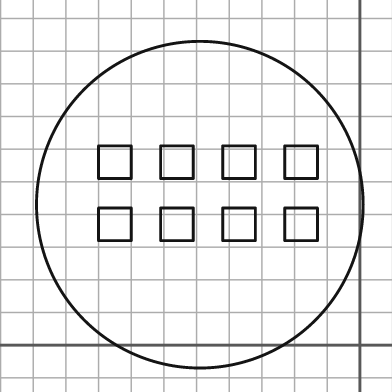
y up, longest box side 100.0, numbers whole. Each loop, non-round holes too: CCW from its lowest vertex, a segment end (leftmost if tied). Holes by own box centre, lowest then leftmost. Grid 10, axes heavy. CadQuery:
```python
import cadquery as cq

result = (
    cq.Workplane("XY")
    .moveTo(-49.0, 43.0)
    .circle(50.0)
    .moveTo(-80.0, 32.0)
    .lineTo(-70.0, 32.0)
    .lineTo(-70.0, 42.0)
    .lineTo(-80.0, 42.0)
    .close()
    .moveTo(-61.0, 32.0)
    .lineTo(-51.0, 32.0)
    .lineTo(-51.0, 42.0)
    .lineTo(-61.0, 42.0)
    .close()
    .moveTo(-42.0, 32.0)
    .lineTo(-32.0, 32.0)
    .lineTo(-32.0, 42.0)
    .lineTo(-42.0, 42.0)
    .close()
    .moveTo(-23.0, 32.0)
    .lineTo(-13.0, 32.0)
    .lineTo(-13.0, 42.0)
    .lineTo(-23.0, 42.0)
    .close()
    .moveTo(-80.0, 51.0)
    .lineTo(-70.0, 51.0)
    .lineTo(-70.0, 61.0)
    .lineTo(-80.0, 61.0)
    .close()
    .moveTo(-61.0, 51.0)
    .lineTo(-51.0, 51.0)
    .lineTo(-51.0, 61.0)
    .lineTo(-61.0, 61.0)
    .close()
    .moveTo(-42.0, 51.0)
    .lineTo(-32.0, 51.0)
    .lineTo(-32.0, 61.0)
    .lineTo(-42.0, 61.0)
    .close()
    .moveTo(-23.0, 51.0)
    .lineTo(-13.0, 51.0)
    .lineTo(-13.0, 61.0)
    .lineTo(-23.0, 61.0)
    .close()
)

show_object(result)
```